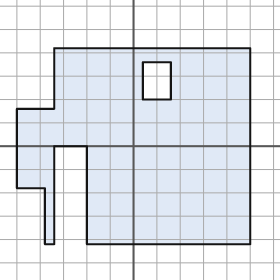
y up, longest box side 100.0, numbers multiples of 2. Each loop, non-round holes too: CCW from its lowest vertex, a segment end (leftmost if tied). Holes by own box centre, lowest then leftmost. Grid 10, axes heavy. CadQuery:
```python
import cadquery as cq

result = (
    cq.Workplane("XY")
    .moveTo(-38.0, -42.0)
    .lineTo(-34.0, -42.0)
    .lineTo(-34.0, 0.0)
    .lineTo(-20.0, 0.0)
    .lineTo(-20.0, -42.0)
    .lineTo(50.0, -42.0)
    .lineTo(50.0, 42.0)
    .lineTo(-34.0, 42.0)
    .lineTo(-34.0, 16.0)
    .lineTo(-50.0, 16.0)
    .lineTo(-50.0, -18.0)
    .lineTo(-38.0, -18.0)
    .close()
    .moveTo(4.0, 20.0)
    .lineTo(16.0, 20.0)
    .lineTo(16.0, 36.0)
    .lineTo(4.0, 36.0)
    .close()
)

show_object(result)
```